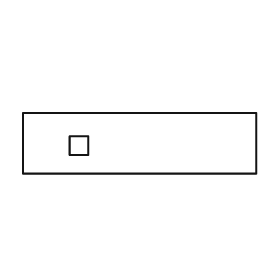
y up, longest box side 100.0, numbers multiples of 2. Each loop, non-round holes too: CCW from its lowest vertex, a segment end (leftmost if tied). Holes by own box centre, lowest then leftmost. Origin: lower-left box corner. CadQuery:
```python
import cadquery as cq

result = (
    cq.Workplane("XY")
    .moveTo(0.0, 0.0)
    .lineTo(100.0, 0.0)
    .lineTo(100.0, 26.0)
    .lineTo(0.0, 26.0)
    .close()
    .moveTo(20.0, 8.0)
    .lineTo(28.0, 8.0)
    .lineTo(28.0, 16.0)
    .lineTo(20.0, 16.0)
    .close()
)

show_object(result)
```